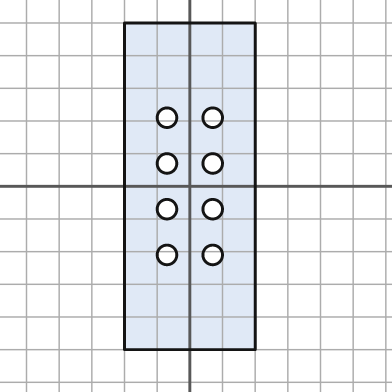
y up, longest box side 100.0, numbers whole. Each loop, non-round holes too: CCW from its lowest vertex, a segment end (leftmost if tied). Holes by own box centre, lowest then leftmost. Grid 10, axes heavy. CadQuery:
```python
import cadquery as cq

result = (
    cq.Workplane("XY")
    .moveTo(-20.0, -50.0)
    .lineTo(20.0, -50.0)
    .lineTo(20.0, 50.0)
    .lineTo(-20.0, 50.0)
    .close()
    .moveTo(-7.0, -21.0)
    .circle(3.0)
    .moveTo(7.0, -21.0)
    .circle(3.0)
    .moveTo(-7.0, -7.0)
    .circle(3.0)
    .moveTo(7.0, -7.0)
    .circle(3.0)
    .moveTo(-7.0, 7.0)
    .circle(3.0)
    .moveTo(7.0, 7.0)
    .circle(3.0)
    .moveTo(-7.0, 21.0)
    .circle(3.0)
    .moveTo(7.0, 21.0)
    .circle(3.0)
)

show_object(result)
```